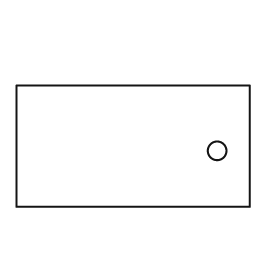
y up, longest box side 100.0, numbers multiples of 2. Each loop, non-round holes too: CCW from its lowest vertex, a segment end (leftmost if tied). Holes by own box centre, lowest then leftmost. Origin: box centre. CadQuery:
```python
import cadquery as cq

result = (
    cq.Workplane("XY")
    .moveTo(-50.0, -26.0)
    .lineTo(50.0, -26.0)
    .lineTo(50.0, 26.0)
    .lineTo(-50.0, 26.0)
    .close()
    .moveTo(36.0, -2.0)
    .circle(4.0)
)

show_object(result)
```